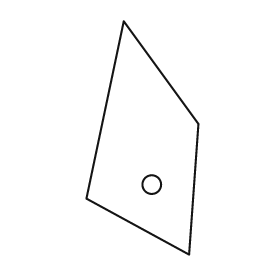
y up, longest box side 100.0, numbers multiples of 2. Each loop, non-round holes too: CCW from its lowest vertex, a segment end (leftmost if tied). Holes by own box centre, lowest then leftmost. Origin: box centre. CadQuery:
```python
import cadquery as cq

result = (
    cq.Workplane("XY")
    .moveTo(20.0, -50.0)
    .lineTo(24.0, 6.0)
    .lineTo(-8.0, 50.0)
    .lineTo(-24.0, -26.0)
    .close()
    .moveTo(4.0, -20.0)
    .circle(4.0)
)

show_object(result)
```